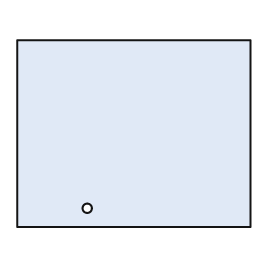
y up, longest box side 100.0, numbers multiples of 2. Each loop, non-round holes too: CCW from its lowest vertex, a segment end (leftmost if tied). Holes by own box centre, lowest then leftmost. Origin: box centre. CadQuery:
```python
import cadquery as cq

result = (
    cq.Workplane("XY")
    .moveTo(-50.0, -40.0)
    .lineTo(50.0, -40.0)
    .lineTo(50.0, 40.0)
    .lineTo(-50.0, 40.0)
    .close()
    .moveTo(-20.0, -32.0)
    .circle(2.0)
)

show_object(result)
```